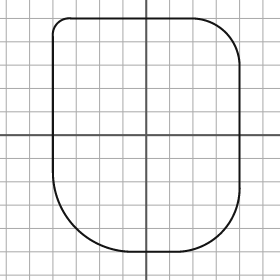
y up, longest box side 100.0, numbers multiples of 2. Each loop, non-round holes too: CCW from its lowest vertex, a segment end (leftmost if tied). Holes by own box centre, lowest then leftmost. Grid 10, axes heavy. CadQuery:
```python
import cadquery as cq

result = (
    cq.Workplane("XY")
    .moveTo(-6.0, -50.0)
    .lineTo(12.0, -50.0)
    .threePointArc((32.0, -42.0), (40.0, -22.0))
    .lineTo(40.0, 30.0)
    .threePointArc((34.0, 44.0), (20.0, 50.0))
    .lineTo(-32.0, 50.0)
    .threePointArc((-38.0, 48.0), (-40.0, 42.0))
    .lineTo(-40.0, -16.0)
    .threePointArc((-30.0, -40.0), (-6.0, -50.0))
    .close()
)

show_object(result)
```